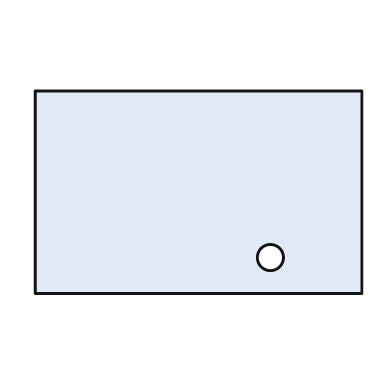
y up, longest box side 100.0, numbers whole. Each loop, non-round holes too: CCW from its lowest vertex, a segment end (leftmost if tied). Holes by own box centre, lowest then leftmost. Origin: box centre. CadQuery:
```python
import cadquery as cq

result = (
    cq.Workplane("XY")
    .moveTo(-50.0, -31.0)
    .lineTo(50.0, -31.0)
    .lineTo(50.0, 31.0)
    .lineTo(-50.0, 31.0)
    .close()
    .moveTo(22.0, -20.0)
    .circle(4.0)
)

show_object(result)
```